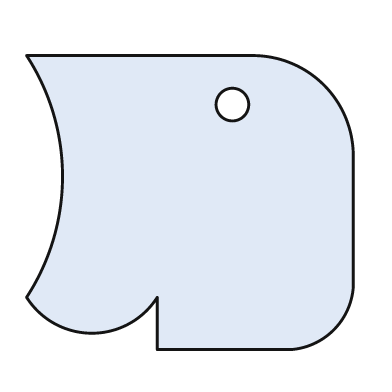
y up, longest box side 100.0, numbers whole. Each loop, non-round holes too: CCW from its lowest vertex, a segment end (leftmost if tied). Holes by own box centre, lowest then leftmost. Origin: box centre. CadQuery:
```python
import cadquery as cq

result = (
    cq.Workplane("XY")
    .moveTo(-10.0, -45.0)
    .lineTo(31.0, -45.0)
    .threePointArc((44.0, -39.0), (50.0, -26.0))
    .lineTo(50.0, 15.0)
    .threePointArc((41.0, 36.0), (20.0, 45.0))
    .lineTo(-50.0, 45.0)
    .threePointArc((-39.0, 8.0), (-50.0, -29.0))
    .threePointArc((-30.0, -40.0), (-10.0, -29.0))
    .close()
    .moveTo(13.0, 30.0)
    .circle(5.0)
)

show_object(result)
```